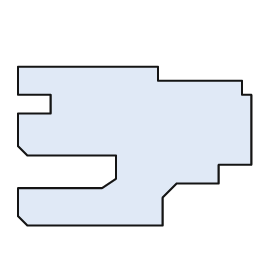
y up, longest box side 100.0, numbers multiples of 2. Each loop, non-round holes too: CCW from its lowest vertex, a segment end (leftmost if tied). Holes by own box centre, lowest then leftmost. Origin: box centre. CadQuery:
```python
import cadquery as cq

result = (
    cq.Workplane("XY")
    .moveTo(-46.0, -34.0)
    .lineTo(12.0, -34.0)
    .lineTo(12.0, -22.0)
    .lineTo(18.0, -16.0)
    .lineTo(36.0, -16.0)
    .lineTo(36.0, -8.0)
    .lineTo(50.0, -8.0)
    .lineTo(50.0, 22.0)
    .lineTo(46.0, 22.0)
    .lineTo(46.0, 28.0)
    .lineTo(10.0, 28.0)
    .lineTo(10.0, 34.0)
    .lineTo(-50.0, 34.0)
    .lineTo(-50.0, 22.0)
    .lineTo(-36.0, 22.0)
    .lineTo(-36.0, 14.0)
    .lineTo(-50.0, 14.0)
    .lineTo(-50.0, 0.0)
    .lineTo(-46.0, -4.0)
    .lineTo(-8.0, -4.0)
    .lineTo(-8.0, -14.0)
    .lineTo(-14.0, -18.0)
    .lineTo(-50.0, -18.0)
    .lineTo(-50.0, -30.0)
    .close()
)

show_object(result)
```